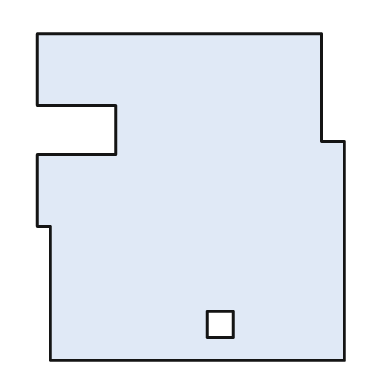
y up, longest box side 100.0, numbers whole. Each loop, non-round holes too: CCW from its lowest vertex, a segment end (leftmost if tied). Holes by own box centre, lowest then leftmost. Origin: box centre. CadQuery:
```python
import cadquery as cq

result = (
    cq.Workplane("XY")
    .moveTo(-43.0, -50.0)
    .lineTo(47.0, -50.0)
    .lineTo(47.0, 17.0)
    .lineTo(40.0, 17.0)
    .lineTo(40.0, 50.0)
    .lineTo(-47.0, 50.0)
    .lineTo(-47.0, 28.0)
    .lineTo(-23.0, 28.0)
    .lineTo(-23.0, 13.0)
    .lineTo(-47.0, 13.0)
    .lineTo(-47.0, -9.0)
    .lineTo(-43.0, -9.0)
    .close()
    .moveTo(5.0, -43.0)
    .lineTo(13.0, -43.0)
    .lineTo(13.0, -35.0)
    .lineTo(5.0, -35.0)
    .close()
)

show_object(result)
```